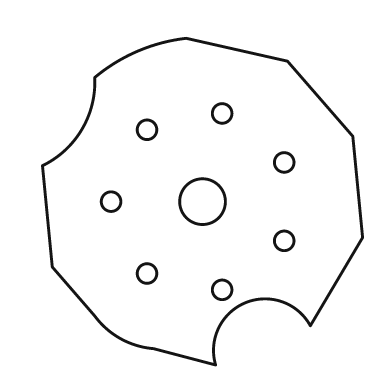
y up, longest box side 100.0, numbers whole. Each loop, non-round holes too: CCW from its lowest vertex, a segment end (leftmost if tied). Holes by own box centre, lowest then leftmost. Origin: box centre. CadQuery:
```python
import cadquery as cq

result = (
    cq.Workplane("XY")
    .moveTo(4.0, -50.0)
    .threePointArc((13.0, -31.0), (33.0, -38.0))
    .lineTo(49.0, -11.0)
    .lineTo(46.0, 20.0)
    .lineTo(26.0, 43.0)
    .lineTo(-5.0, 50.0)
    .threePointArc((-20.0, 46.0), (-33.0, 38.0))
    .threePointArc((-37.0, 22.0), (-49.0, 11.0))
    .lineTo(-46.0, -20.0)
    .lineTo(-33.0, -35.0)
    .threePointArc((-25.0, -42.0), (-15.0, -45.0))
    .close()
    .moveTo(6.0, -27.0)
    .circle(3.0)
    .moveTo(-17.0, -22.0)
    .circle(3.0)
    .moveTo(25.0, -12.0)
    .circle(3.0)
    .moveTo(-28.0, 0.0)
    .circle(3.0)
    .moveTo(0.0, 0.0)
    .circle(7.0)
    .moveTo(25.0, 12.0)
    .circle(3.0)
    .moveTo(-17.0, 22.0)
    .circle(3.0)
    .moveTo(6.0, 27.0)
    .circle(3.0)
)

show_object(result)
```